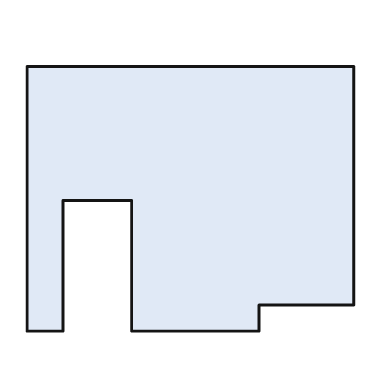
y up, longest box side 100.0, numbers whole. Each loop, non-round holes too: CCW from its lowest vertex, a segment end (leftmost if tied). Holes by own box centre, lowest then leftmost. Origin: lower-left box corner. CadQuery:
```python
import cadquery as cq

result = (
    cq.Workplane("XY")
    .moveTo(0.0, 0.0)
    .lineTo(11.0, 0.0)
    .lineTo(11.0, 40.0)
    .lineTo(32.0, 40.0)
    .lineTo(32.0, 0.0)
    .lineTo(71.0, 0.0)
    .lineTo(71.0, 8.0)
    .lineTo(100.0, 8.0)
    .lineTo(100.0, 81.0)
    .lineTo(0.0, 81.0)
    .close()
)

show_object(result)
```